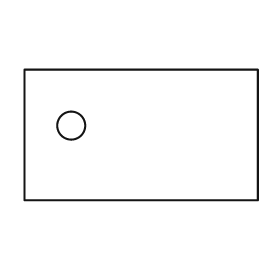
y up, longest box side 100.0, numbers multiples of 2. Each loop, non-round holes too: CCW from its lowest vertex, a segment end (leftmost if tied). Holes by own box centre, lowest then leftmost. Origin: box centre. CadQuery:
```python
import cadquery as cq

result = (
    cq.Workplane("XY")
    .moveTo(-50.0, -28.0)
    .lineTo(50.0, -28.0)
    .lineTo(50.0, 28.0)
    .lineTo(-50.0, 28.0)
    .close()
    .moveTo(-30.0, 4.0)
    .circle(6.0)
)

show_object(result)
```